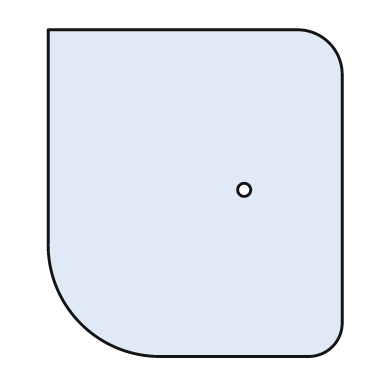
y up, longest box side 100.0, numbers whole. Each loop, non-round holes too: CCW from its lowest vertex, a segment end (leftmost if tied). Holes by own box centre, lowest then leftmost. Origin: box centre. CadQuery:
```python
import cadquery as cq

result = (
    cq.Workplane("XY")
    .moveTo(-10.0, -50.0)
    .lineTo(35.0, -50.0)
    .threePointArc((42.0, -47.0), (45.0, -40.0))
    .lineTo(45.0, 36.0)
    .threePointArc((41.0, 46.0), (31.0, 50.0))
    .lineTo(-45.0, 50.0)
    .lineTo(-45.0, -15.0)
    .threePointArc((-35.0, -40.0), (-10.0, -50.0))
    .close()
    .moveTo(15.0, 1.0)
    .circle(2.0)
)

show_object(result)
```